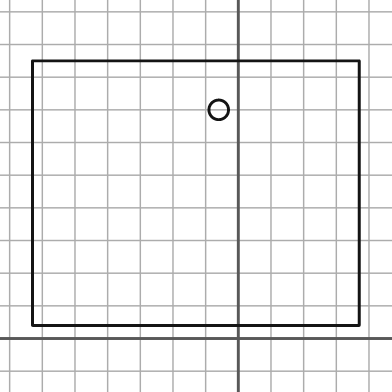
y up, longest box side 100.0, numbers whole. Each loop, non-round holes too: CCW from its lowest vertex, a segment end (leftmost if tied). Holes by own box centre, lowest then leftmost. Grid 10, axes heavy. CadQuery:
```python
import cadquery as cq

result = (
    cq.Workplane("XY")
    .moveTo(-63.0, 4.0)
    .lineTo(37.0, 4.0)
    .lineTo(37.0, 85.0)
    .lineTo(-63.0, 85.0)
    .close()
    .moveTo(-6.0, 70.0)
    .circle(3.0)
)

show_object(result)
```